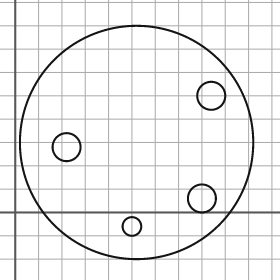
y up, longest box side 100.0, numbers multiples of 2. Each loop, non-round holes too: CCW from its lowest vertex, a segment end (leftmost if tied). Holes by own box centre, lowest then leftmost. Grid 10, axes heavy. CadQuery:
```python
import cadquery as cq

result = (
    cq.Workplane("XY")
    .moveTo(52.0, 30.0)
    .circle(50.0)
    .moveTo(50.0, -6.0)
    .circle(4.0)
    .moveTo(80.0, 6.0)
    .circle(6.0)
    .moveTo(22.0, 28.0)
    .circle(6.0)
    .moveTo(84.0, 50.0)
    .circle(6.0)
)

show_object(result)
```